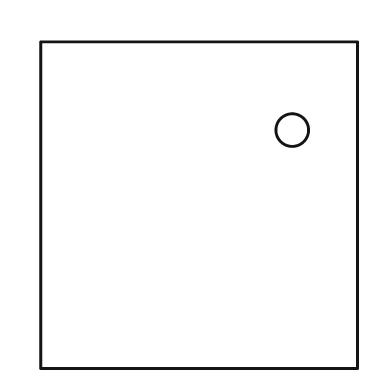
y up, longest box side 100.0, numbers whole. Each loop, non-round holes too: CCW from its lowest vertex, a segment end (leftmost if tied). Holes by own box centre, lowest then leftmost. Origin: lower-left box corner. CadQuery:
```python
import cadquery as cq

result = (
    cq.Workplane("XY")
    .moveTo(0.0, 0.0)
    .lineTo(97.0, 0.0)
    .lineTo(97.0, 100.0)
    .lineTo(0.0, 100.0)
    .close()
    .moveTo(77.0, 73.0)
    .circle(5.0)
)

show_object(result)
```